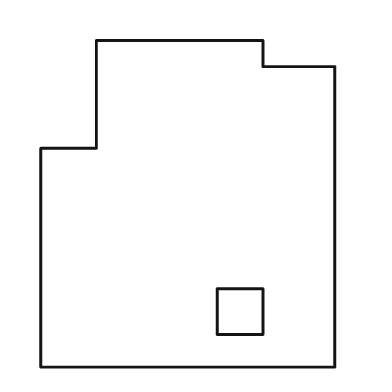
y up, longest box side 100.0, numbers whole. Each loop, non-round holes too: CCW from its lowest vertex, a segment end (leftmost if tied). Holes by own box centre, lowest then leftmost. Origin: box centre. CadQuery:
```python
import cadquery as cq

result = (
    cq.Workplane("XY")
    .moveTo(-45.0, -50.0)
    .lineTo(45.0, -50.0)
    .lineTo(45.0, 42.0)
    .lineTo(23.0, 42.0)
    .lineTo(23.0, 50.0)
    .lineTo(-28.0, 50.0)
    .lineTo(-28.0, 17.0)
    .lineTo(-45.0, 17.0)
    .close()
    .moveTo(9.0, -40.0)
    .lineTo(23.0, -40.0)
    .lineTo(23.0, -26.0)
    .lineTo(9.0, -26.0)
    .close()
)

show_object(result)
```